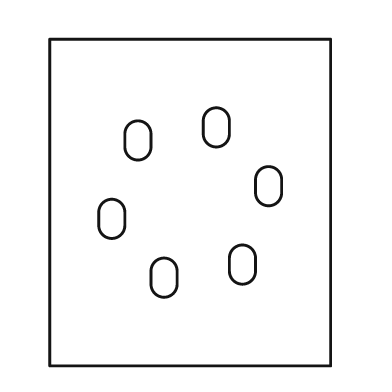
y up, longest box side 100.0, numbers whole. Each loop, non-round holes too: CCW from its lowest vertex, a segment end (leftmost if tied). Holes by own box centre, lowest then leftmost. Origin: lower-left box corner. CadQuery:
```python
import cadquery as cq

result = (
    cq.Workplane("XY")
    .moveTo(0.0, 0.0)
    .lineTo(86.0, 0.0)
    .lineTo(86.0, 100.0)
    .lineTo(0.0, 100.0)
    .close()
    .moveTo(31.0, 25.0)
    .threePointArc((35.0, 21.0), (39.0, 25.0))
    .lineTo(39.0, 29.0)
    .threePointArc((35.0, 33.0), (31.0, 29.0))
    .close()
    .moveTo(55.0, 29.0)
    .threePointArc((59.0, 25.0), (63.0, 29.0))
    .lineTo(63.0, 33.0)
    .threePointArc((59.0, 37.0), (55.0, 33.0))
    .close()
    .moveTo(15.0, 43.0)
    .threePointArc((19.0, 39.0), (23.0, 43.0))
    .lineTo(23.0, 47.0)
    .threePointArc((19.0, 51.0), (15.0, 47.0))
    .close()
    .moveTo(63.0, 53.0)
    .threePointArc((67.0, 49.0), (71.0, 53.0))
    .lineTo(71.0, 57.0)
    .threePointArc((67.0, 61.0), (63.0, 57.0))
    .close()
    .moveTo(23.0, 67.0)
    .threePointArc((27.0, 63.0), (31.0, 67.0))
    .lineTo(31.0, 71.0)
    .threePointArc((27.0, 75.0), (23.0, 71.0))
    .close()
    .moveTo(47.0, 71.0)
    .threePointArc((51.0, 67.0), (55.0, 71.0))
    .lineTo(55.0, 75.0)
    .threePointArc((51.0, 79.0), (47.0, 75.0))
    .close()
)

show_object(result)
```